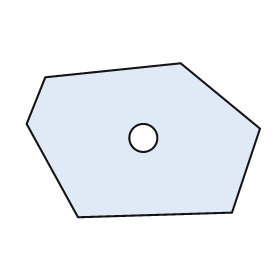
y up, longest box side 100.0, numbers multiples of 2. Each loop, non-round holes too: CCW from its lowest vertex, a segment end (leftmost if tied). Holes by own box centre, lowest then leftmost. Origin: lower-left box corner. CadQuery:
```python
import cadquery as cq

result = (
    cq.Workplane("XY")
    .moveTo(22.0, 0.0)
    .lineTo(88.0, 2.0)
    .lineTo(100.0, 38.0)
    .lineTo(66.0, 66.0)
    .lineTo(8.0, 60.0)
    .lineTo(0.0, 40.0)
    .close()
    .moveTo(50.0, 34.0)
    .circle(6.0)
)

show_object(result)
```